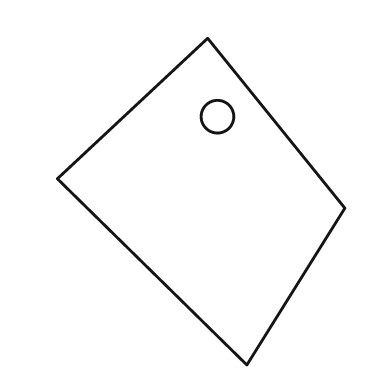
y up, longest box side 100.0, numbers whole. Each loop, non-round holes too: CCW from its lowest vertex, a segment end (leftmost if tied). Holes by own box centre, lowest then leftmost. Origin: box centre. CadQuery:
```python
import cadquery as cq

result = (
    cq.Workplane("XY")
    .moveTo(14.0, -50.0)
    .lineTo(44.0, -2.0)
    .lineTo(2.0, 50.0)
    .lineTo(-44.0, 7.0)
    .close()
    .moveTo(5.0, 26.0)
    .circle(5.0)
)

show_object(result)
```